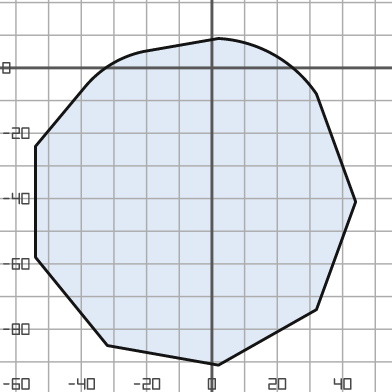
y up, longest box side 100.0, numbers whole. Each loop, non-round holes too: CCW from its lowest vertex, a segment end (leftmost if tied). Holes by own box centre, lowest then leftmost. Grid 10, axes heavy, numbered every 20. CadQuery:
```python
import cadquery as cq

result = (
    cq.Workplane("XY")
    .moveTo(2.0, -91.0)
    .lineTo(32.0, -74.0)
    .lineTo(44.0, -41.0)
    .lineTo(32.0, -8.0)
    .threePointArc((19.0, 4.0), (2.0, 9.0))
    .lineTo(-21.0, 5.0)
    .threePointArc((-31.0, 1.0), (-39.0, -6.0))
    .lineTo(-54.0, -24.0)
    .lineTo(-54.0, -58.0)
    .lineTo(-32.0, -85.0)
    .close()
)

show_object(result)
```